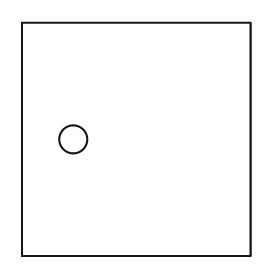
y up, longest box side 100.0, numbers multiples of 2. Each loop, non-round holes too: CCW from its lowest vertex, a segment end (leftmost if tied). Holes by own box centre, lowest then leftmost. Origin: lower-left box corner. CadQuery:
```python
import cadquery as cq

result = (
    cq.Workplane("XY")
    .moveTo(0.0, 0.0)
    .lineTo(98.0, 0.0)
    .lineTo(98.0, 100.0)
    .lineTo(0.0, 100.0)
    .close()
    .moveTo(22.0, 50.0)
    .circle(6.0)
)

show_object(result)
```